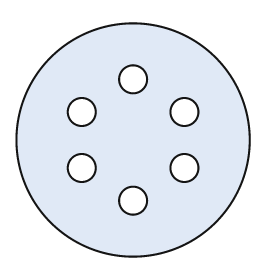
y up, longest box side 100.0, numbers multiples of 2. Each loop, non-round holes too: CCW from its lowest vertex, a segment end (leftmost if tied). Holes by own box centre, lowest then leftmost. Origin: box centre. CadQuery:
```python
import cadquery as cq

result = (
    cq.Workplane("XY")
    .moveTo(0.0, 0.0)
    .circle(50.0)
    .moveTo(0.0, -26.0)
    .circle(6.0)
    .moveTo(-22.0, -12.0)
    .circle(6.0)
    .moveTo(22.0, -12.0)
    .circle(6.0)
    .moveTo(-22.0, 12.0)
    .circle(6.0)
    .moveTo(22.0, 12.0)
    .circle(6.0)
    .moveTo(0.0, 26.0)
    .circle(6.0)
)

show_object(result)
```